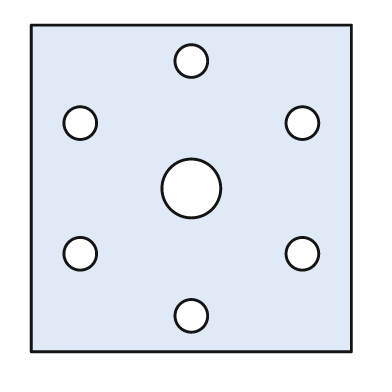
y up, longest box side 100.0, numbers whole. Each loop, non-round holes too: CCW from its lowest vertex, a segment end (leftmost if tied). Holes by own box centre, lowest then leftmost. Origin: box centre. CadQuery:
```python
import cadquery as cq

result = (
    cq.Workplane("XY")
    .moveTo(-49.0, -50.0)
    .lineTo(49.0, -50.0)
    .lineTo(49.0, 50.0)
    .lineTo(-49.0, 50.0)
    .close()
    .moveTo(0.0, -39.0)
    .circle(5.0)
    .moveTo(-34.0, -20.0)
    .circle(5.0)
    .moveTo(34.0, -20.0)
    .circle(5.0)
    .moveTo(0.0, 0.0)
    .circle(9.0)
    .moveTo(-34.0, 20.0)
    .circle(5.0)
    .moveTo(34.0, 20.0)
    .circle(5.0)
    .moveTo(0.0, 39.0)
    .circle(5.0)
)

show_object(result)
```